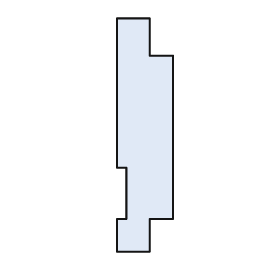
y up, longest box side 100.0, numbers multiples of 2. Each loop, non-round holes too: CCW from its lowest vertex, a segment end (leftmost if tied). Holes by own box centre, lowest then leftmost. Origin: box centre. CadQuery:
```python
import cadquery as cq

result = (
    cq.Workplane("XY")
    .moveTo(-12.0, -50.0)
    .lineTo(2.0, -50.0)
    .lineTo(2.0, -36.0)
    .lineTo(12.0, -36.0)
    .lineTo(12.0, 34.0)
    .lineTo(2.0, 34.0)
    .lineTo(2.0, 50.0)
    .lineTo(-12.0, 50.0)
    .lineTo(-12.0, -14.0)
    .lineTo(-8.0, -14.0)
    .lineTo(-8.0, -36.0)
    .lineTo(-12.0, -36.0)
    .close()
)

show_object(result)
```